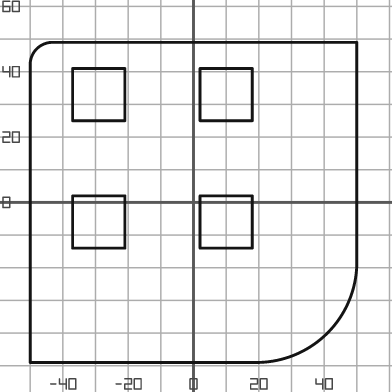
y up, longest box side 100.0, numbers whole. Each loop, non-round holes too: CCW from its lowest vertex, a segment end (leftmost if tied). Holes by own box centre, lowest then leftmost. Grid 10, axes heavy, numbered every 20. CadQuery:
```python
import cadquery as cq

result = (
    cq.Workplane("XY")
    .moveTo(-50.0, -49.0)
    .lineTo(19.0, -49.0)
    .threePointArc((41.0, -40.0), (50.0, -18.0))
    .lineTo(50.0, 49.0)
    .lineTo(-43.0, 49.0)
    .threePointArc((-48.0, 47.0), (-50.0, 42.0))
    .close()
    .moveTo(-37.0, -14.0)
    .lineTo(-21.0, -14.0)
    .lineTo(-21.0, 2.0)
    .lineTo(-37.0, 2.0)
    .close()
    .moveTo(2.0, -14.0)
    .lineTo(18.0, -14.0)
    .lineTo(18.0, 2.0)
    .lineTo(2.0, 2.0)
    .close()
    .moveTo(-37.0, 25.0)
    .lineTo(-21.0, 25.0)
    .lineTo(-21.0, 41.0)
    .lineTo(-37.0, 41.0)
    .close()
    .moveTo(2.0, 25.0)
    .lineTo(18.0, 25.0)
    .lineTo(18.0, 41.0)
    .lineTo(2.0, 41.0)
    .close()
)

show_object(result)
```